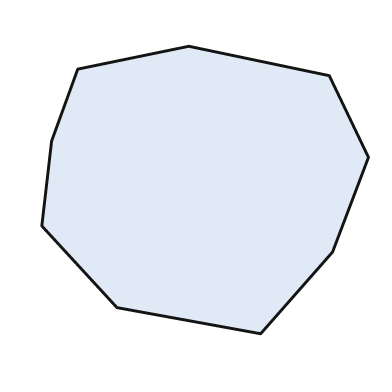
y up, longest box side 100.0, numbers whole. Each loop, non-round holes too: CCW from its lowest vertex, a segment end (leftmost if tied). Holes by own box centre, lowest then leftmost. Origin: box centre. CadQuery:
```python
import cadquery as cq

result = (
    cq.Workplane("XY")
    .moveTo(17.0, -44.0)
    .lineTo(39.0, -19.0)
    .lineTo(50.0, 10.0)
    .lineTo(38.0, 35.0)
    .lineTo(-5.0, 44.0)
    .lineTo(-39.0, 37.0)
    .lineTo(-47.0, 15.0)
    .lineTo(-50.0, -11.0)
    .lineTo(-27.0, -36.0)
    .close()
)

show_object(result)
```